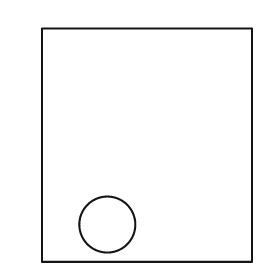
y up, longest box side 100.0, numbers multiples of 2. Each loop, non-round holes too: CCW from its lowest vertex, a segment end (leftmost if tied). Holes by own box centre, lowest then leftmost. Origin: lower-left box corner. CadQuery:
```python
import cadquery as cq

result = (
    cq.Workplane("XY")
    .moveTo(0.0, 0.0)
    .lineTo(90.0, 0.0)
    .lineTo(90.0, 100.0)
    .lineTo(0.0, 100.0)
    .close()
    .moveTo(28.0, 16.0)
    .circle(12.0)
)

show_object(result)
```